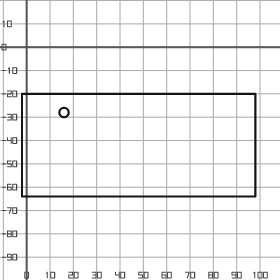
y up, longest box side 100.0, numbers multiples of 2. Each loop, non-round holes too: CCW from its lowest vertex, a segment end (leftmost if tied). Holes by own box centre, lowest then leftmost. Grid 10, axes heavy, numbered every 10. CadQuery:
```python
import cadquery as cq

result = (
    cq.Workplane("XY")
    .moveTo(-2.0, -64.0)
    .lineTo(98.0, -64.0)
    .lineTo(98.0, -20.0)
    .lineTo(-2.0, -20.0)
    .close()
    .moveTo(16.0, -28.0)
    .circle(2.0)
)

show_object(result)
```